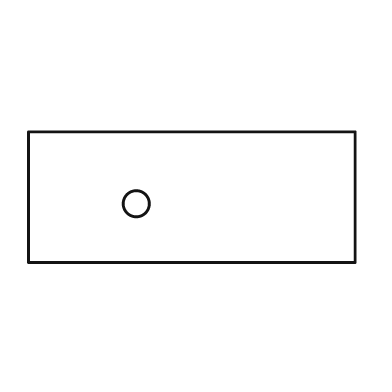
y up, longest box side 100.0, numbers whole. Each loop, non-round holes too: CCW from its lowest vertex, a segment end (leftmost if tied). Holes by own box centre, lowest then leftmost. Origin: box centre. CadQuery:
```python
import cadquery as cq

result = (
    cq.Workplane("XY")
    .moveTo(-50.0, -20.0)
    .lineTo(50.0, -20.0)
    .lineTo(50.0, 20.0)
    .lineTo(-50.0, 20.0)
    .close()
    .moveTo(-17.0, -2.0)
    .circle(4.0)
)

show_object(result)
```